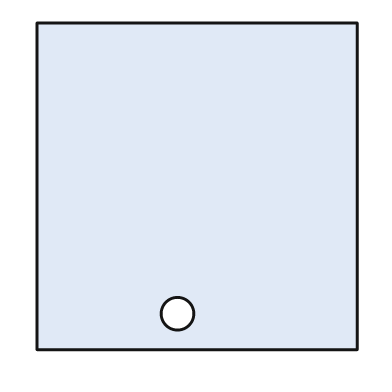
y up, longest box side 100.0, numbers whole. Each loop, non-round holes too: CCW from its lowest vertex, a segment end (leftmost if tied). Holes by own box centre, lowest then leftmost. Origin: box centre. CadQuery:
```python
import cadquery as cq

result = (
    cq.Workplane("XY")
    .moveTo(-49.0, -50.0)
    .lineTo(49.0, -50.0)
    .lineTo(49.0, 50.0)
    .lineTo(-49.0, 50.0)
    .close()
    .moveTo(-6.0, -39.0)
    .circle(5.0)
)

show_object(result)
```